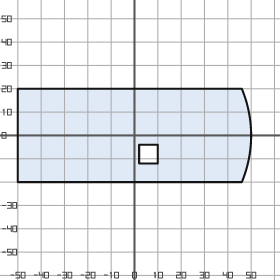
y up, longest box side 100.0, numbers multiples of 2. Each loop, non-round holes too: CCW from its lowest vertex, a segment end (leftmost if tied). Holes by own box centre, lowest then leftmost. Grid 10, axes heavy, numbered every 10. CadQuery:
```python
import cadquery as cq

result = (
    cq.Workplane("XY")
    .moveTo(-50.0, -20.0)
    .lineTo(46.0, -20.0)
    .threePointArc((50.0, 0.0), (46.0, 20.0))
    .lineTo(-50.0, 20.0)
    .close()
    .moveTo(2.0, -12.0)
    .lineTo(10.0, -12.0)
    .lineTo(10.0, -4.0)
    .lineTo(2.0, -4.0)
    .close()
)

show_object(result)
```